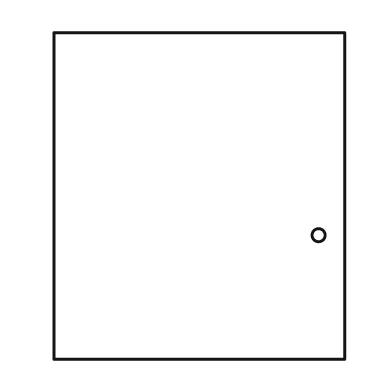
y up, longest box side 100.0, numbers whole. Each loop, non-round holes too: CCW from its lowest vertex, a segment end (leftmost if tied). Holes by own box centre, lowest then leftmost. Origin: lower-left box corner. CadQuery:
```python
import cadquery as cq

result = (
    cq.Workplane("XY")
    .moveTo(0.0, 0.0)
    .lineTo(89.0, 0.0)
    .lineTo(89.0, 100.0)
    .lineTo(0.0, 100.0)
    .close()
    .moveTo(81.0, 38.0)
    .circle(2.0)
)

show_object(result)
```